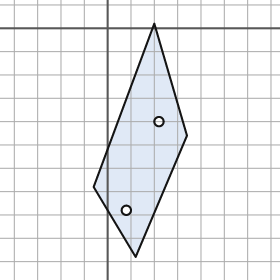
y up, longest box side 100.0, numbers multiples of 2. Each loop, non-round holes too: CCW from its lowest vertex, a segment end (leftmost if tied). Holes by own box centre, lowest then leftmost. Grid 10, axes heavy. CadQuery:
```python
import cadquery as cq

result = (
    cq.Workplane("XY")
    .moveTo(12.0, -98.0)
    .lineTo(34.0, -46.0)
    .lineTo(20.0, 2.0)
    .lineTo(-6.0, -68.0)
    .close()
    .moveTo(8.0, -78.0)
    .circle(2.0)
    .moveTo(22.0, -40.0)
    .circle(2.0)
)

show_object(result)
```